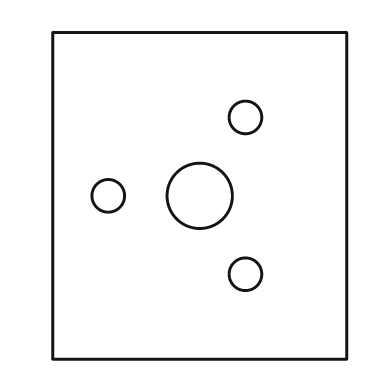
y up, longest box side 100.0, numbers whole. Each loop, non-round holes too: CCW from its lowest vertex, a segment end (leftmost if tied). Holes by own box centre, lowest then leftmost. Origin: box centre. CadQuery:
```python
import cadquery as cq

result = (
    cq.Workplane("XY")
    .moveTo(-45.0, -50.0)
    .lineTo(45.0, -50.0)
    .lineTo(45.0, 50.0)
    .lineTo(-45.0, 50.0)
    .close()
    .moveTo(14.0, -24.0)
    .circle(5.0)
    .moveTo(-28.0, 0.0)
    .circle(5.0)
    .moveTo(0.0, 0.0)
    .circle(10.0)
    .moveTo(14.0, 24.0)
    .circle(5.0)
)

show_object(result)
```